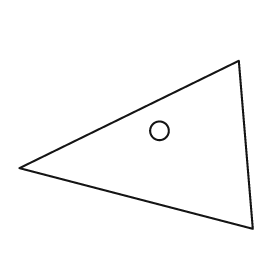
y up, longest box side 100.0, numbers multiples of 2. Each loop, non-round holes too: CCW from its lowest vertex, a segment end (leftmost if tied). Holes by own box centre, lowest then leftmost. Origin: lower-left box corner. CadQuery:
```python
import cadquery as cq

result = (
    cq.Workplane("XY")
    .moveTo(100.0, 0.0)
    .lineTo(94.0, 72.0)
    .lineTo(0.0, 26.0)
    .close()
    .moveTo(60.0, 42.0)
    .circle(4.0)
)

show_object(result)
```